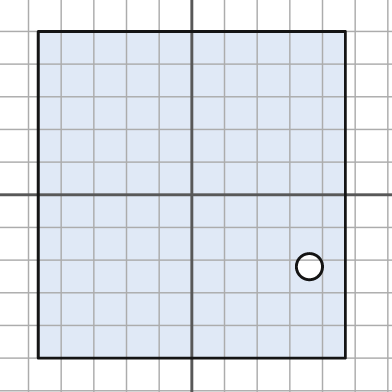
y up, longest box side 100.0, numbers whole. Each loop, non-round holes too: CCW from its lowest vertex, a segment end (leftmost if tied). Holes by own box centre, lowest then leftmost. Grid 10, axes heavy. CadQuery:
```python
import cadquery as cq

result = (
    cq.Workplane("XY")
    .moveTo(-47.0, -50.0)
    .lineTo(47.0, -50.0)
    .lineTo(47.0, 50.0)
    .lineTo(-47.0, 50.0)
    .close()
    .moveTo(36.0, -22.0)
    .circle(4.0)
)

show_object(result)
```